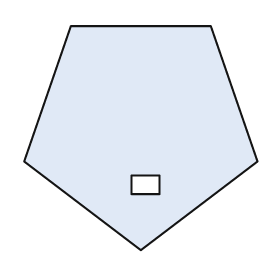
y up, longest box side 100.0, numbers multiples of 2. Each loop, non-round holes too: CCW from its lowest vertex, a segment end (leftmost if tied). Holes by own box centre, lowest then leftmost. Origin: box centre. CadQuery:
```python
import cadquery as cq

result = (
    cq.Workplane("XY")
    .moveTo(0.0, -48.0)
    .lineTo(50.0, -10.0)
    .lineTo(30.0, 48.0)
    .lineTo(-30.0, 48.0)
    .lineTo(-50.0, -10.0)
    .close()
    .moveTo(-4.0, -24.0)
    .lineTo(8.0, -24.0)
    .lineTo(8.0, -16.0)
    .lineTo(-4.0, -16.0)
    .close()
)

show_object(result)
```